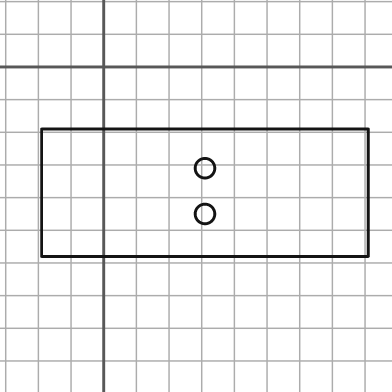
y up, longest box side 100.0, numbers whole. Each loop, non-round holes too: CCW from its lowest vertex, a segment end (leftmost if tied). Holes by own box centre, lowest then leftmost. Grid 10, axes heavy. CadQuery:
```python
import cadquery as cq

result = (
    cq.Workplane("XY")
    .moveTo(-19.0, -58.0)
    .lineTo(81.0, -58.0)
    .lineTo(81.0, -19.0)
    .lineTo(-19.0, -19.0)
    .close()
    .moveTo(31.0, -45.0)
    .circle(3.0)
    .moveTo(31.0, -31.0)
    .circle(3.0)
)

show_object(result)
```